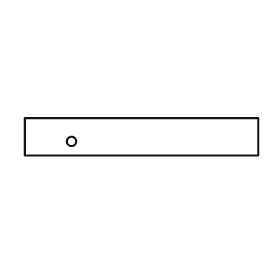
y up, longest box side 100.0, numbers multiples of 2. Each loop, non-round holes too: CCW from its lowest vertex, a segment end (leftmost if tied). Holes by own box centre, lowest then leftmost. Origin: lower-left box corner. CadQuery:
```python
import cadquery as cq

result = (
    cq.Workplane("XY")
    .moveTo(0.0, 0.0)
    .lineTo(100.0, 0.0)
    .lineTo(100.0, 16.0)
    .lineTo(0.0, 16.0)
    .close()
    .moveTo(20.0, 6.0)
    .circle(2.0)
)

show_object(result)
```